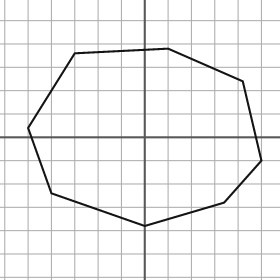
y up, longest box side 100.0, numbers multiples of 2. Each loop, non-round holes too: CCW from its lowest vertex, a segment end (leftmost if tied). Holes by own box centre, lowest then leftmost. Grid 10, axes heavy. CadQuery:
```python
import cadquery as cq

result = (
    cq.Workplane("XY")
    .moveTo(0.0, -38.0)
    .lineTo(34.0, -28.0)
    .lineTo(50.0, -10.0)
    .lineTo(42.0, 24.0)
    .lineTo(10.0, 38.0)
    .lineTo(-30.0, 36.0)
    .lineTo(-50.0, 4.0)
    .lineTo(-40.0, -24.0)
    .close()
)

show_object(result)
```